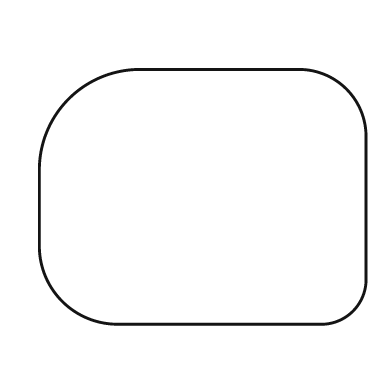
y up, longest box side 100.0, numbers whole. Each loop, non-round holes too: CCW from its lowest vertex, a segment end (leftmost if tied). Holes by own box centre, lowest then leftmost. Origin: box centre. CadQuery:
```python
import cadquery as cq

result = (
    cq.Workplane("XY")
    .moveTo(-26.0, -39.0)
    .lineTo(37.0, -39.0)
    .threePointArc((46.0, -35.0), (50.0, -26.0))
    .lineTo(50.0, 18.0)
    .threePointArc((44.0, 33.0), (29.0, 39.0))
    .lineTo(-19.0, 39.0)
    .threePointArc((-41.0, 30.0), (-50.0, 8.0))
    .lineTo(-50.0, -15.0)
    .threePointArc((-43.0, -32.0), (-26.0, -39.0))
    .close()
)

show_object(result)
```